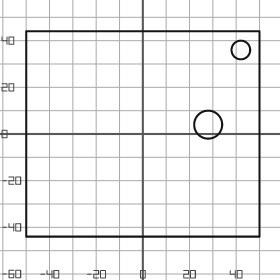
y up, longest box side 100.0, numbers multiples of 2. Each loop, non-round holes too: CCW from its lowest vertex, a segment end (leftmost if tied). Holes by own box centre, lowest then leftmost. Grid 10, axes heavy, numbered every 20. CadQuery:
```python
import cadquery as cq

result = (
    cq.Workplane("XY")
    .moveTo(-50.0, -44.0)
    .lineTo(50.0, -44.0)
    .lineTo(50.0, 44.0)
    .lineTo(-50.0, 44.0)
    .close()
    .moveTo(28.0, 4.0)
    .circle(6.0)
    .moveTo(42.0, 36.0)
    .circle(4.0)
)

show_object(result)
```